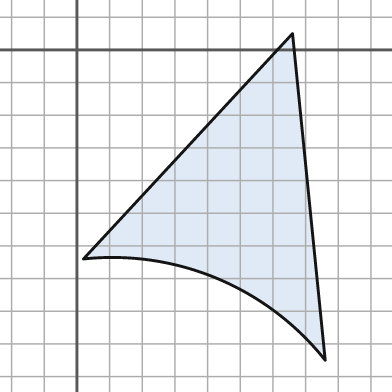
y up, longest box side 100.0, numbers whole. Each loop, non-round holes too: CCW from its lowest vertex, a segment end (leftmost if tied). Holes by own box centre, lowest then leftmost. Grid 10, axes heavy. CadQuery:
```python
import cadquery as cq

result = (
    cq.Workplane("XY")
    .moveTo(76.0, -95.0)
    .lineTo(66.0, 5.0)
    .lineTo(2.0, -64.0)
    .threePointArc((43.0, -70.0), (76.0, -95.0))
    .close()
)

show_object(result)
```